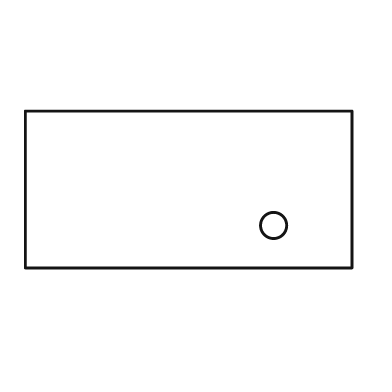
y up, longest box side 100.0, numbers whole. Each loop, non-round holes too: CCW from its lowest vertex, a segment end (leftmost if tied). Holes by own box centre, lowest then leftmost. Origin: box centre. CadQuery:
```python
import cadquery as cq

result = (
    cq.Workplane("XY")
    .moveTo(-50.0, -24.0)
    .lineTo(50.0, -24.0)
    .lineTo(50.0, 24.0)
    .lineTo(-50.0, 24.0)
    .close()
    .moveTo(26.0, -11.0)
    .circle(4.0)
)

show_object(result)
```